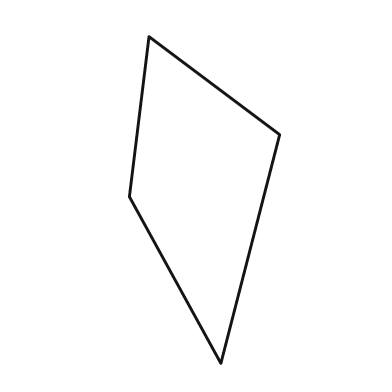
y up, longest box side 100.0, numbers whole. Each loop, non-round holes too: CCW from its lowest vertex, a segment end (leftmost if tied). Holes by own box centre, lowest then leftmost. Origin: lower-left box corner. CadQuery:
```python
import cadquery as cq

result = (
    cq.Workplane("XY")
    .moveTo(28.0, 0.0)
    .lineTo(46.0, 70.0)
    .lineTo(6.0, 100.0)
    .lineTo(0.0, 51.0)
    .close()
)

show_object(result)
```